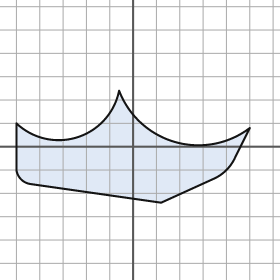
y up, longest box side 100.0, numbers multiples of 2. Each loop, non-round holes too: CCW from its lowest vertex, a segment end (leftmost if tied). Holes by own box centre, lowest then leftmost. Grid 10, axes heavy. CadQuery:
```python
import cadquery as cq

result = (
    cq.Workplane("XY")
    .moveTo(12.0, -24.0)
    .lineTo(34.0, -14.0)
    .threePointArc((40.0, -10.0), (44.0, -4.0))
    .lineTo(50.0, 8.0)
    .threePointArc((18.0, 2.0), (-6.0, 24.0))
    .threePointArc((-24.0, 4.0), (-50.0, 10.0))
    .lineTo(-50.0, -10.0)
    .threePointArc((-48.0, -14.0), (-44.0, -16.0))
    .close()
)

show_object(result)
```